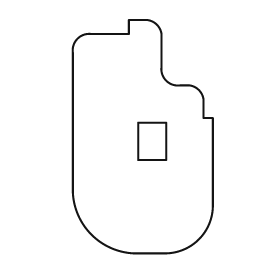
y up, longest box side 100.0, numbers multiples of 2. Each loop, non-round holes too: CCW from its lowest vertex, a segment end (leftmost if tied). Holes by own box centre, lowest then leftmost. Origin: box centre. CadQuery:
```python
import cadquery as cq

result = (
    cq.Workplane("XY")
    .moveTo(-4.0, -50.0)
    .lineTo(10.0, -50.0)
    .threePointArc((24.0, -44.0), (30.0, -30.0))
    .lineTo(30.0, 8.0)
    .lineTo(26.0, 8.0)
    .lineTo(26.0, 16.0)
    .threePointArc((24.0, 20.0), (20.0, 22.0))
    .lineTo(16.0, 22.0)
    .threePointArc((10.0, 24.0), (8.0, 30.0))
    .lineTo(8.0, 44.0)
    .threePointArc((6.0, 48.0), (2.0, 50.0))
    .lineTo(-6.0, 50.0)
    .lineTo(-6.0, 44.0)
    .lineTo(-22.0, 44.0)
    .threePointArc((-28.0, 42.0), (-30.0, 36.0))
    .lineTo(-30.0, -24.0)
    .threePointArc((-22.0, -42.0), (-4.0, -50.0))
    .close()
    .moveTo(-2.0, -10.0)
    .lineTo(10.0, -10.0)
    .lineTo(10.0, 6.0)
    .lineTo(-2.0, 6.0)
    .close()
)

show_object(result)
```